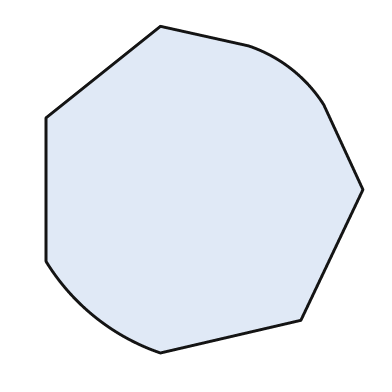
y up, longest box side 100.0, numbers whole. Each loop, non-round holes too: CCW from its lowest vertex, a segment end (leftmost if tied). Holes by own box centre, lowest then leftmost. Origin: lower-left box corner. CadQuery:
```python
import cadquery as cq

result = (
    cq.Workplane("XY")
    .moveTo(35.0, 0.0)
    .lineTo(78.0, 10.0)
    .lineTo(97.0, 50.0)
    .lineTo(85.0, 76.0)
    .threePointArc((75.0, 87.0), (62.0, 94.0))
    .lineTo(35.0, 100.0)
    .lineTo(0.0, 72.0)
    .lineTo(0.0, 28.0)
    .threePointArc((15.0, 11.0), (35.0, 0.0))
    .close()
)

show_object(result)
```